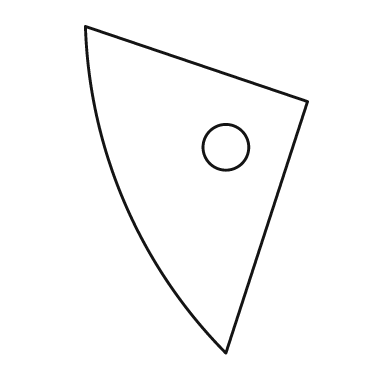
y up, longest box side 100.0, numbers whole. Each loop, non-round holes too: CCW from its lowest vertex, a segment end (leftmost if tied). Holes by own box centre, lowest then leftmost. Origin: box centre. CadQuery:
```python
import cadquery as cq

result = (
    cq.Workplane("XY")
    .moveTo(9.0, -50.0)
    .lineTo(34.0, 27.0)
    .lineTo(-34.0, 50.0)
    .threePointArc((-22.0, -4.0), (9.0, -50.0))
    .close()
    .moveTo(9.0, 13.0)
    .circle(7.0)
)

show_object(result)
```